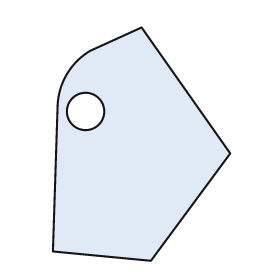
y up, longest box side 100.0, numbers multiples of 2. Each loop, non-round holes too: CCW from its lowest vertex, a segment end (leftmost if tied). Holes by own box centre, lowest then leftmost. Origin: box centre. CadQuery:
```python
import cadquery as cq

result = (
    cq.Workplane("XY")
    .moveTo(4.0, -50.0)
    .lineTo(38.0, -4.0)
    .lineTo(0.0, 50.0)
    .lineTo(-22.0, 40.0)
    .threePointArc((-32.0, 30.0), (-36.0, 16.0))
    .lineTo(-38.0, -46.0)
    .close()
    .moveTo(-24.0, 14.0)
    .circle(8.0)
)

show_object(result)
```